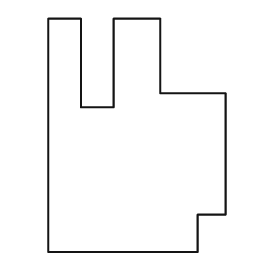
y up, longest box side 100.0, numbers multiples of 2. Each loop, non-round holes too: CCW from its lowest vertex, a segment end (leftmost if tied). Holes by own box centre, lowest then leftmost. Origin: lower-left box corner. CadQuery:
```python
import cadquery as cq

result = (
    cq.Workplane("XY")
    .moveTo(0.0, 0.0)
    .lineTo(64.0, 0.0)
    .lineTo(64.0, 16.0)
    .lineTo(76.0, 16.0)
    .lineTo(76.0, 68.0)
    .lineTo(48.0, 68.0)
    .lineTo(48.0, 100.0)
    .lineTo(28.0, 100.0)
    .lineTo(28.0, 62.0)
    .lineTo(14.0, 62.0)
    .lineTo(14.0, 100.0)
    .lineTo(0.0, 100.0)
    .close()
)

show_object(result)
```